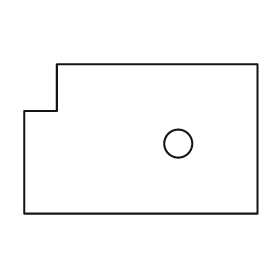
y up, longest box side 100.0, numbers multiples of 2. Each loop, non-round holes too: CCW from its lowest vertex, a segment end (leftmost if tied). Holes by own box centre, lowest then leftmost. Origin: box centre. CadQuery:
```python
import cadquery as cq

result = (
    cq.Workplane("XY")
    .moveTo(-50.0, -32.0)
    .lineTo(50.0, -32.0)
    .lineTo(50.0, 32.0)
    .lineTo(-36.0, 32.0)
    .lineTo(-36.0, 12.0)
    .lineTo(-50.0, 12.0)
    .close()
    .moveTo(16.0, -2.0)
    .circle(6.0)
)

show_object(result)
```